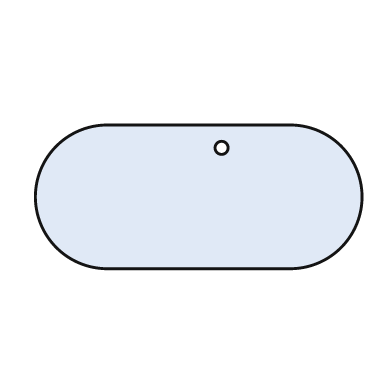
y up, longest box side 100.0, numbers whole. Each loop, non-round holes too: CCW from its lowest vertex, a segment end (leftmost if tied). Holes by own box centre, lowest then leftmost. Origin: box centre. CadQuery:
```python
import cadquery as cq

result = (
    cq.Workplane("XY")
    .moveTo(-28.0, -22.0)
    .lineTo(28.0, -22.0)
    .threePointArc((50.0, 0.0), (28.0, 22.0))
    .lineTo(-28.0, 22.0)
    .threePointArc((-50.0, 0.0), (-28.0, -22.0))
    .close()
    .moveTo(7.0, 15.0)
    .circle(2.0)
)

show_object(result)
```